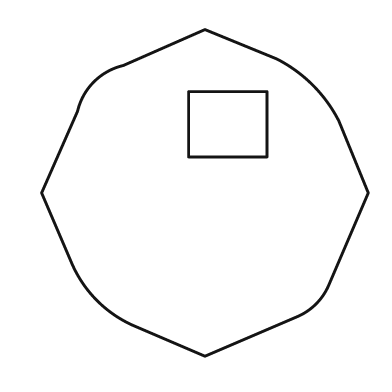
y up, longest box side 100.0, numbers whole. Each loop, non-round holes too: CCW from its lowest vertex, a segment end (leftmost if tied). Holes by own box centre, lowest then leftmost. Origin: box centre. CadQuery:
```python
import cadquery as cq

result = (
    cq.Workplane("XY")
    .moveTo(0.0, -50.0)
    .lineTo(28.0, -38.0)
    .threePointArc((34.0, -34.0), (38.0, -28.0))
    .lineTo(50.0, 0.0)
    .lineTo(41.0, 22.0)
    .threePointArc((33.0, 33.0), (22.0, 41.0))
    .lineTo(0.0, 50.0)
    .lineTo(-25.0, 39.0)
    .threePointArc((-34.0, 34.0), (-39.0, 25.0))
    .lineTo(-50.0, 0.0)
    .lineTo(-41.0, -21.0)
    .threePointArc((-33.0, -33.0), (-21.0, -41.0))
    .close()
    .moveTo(-5.0, 11.0)
    .lineTo(19.0, 11.0)
    .lineTo(19.0, 31.0)
    .lineTo(-5.0, 31.0)
    .close()
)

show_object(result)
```